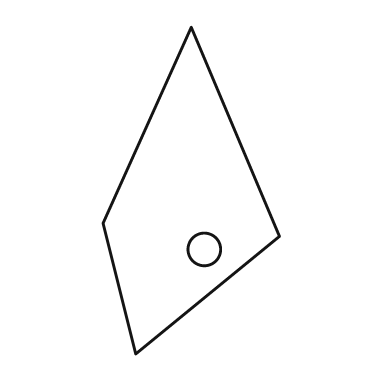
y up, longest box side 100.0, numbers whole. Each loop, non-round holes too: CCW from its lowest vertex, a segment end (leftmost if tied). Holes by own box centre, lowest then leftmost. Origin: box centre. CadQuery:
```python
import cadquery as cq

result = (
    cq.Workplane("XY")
    .moveTo(-17.0, -50.0)
    .lineTo(27.0, -14.0)
    .lineTo(0.0, 50.0)
    .lineTo(-27.0, -10.0)
    .close()
    .moveTo(4.0, -18.0)
    .circle(5.0)
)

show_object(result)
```